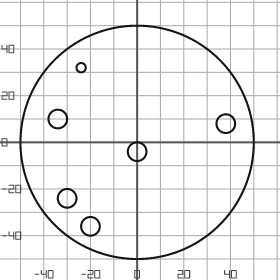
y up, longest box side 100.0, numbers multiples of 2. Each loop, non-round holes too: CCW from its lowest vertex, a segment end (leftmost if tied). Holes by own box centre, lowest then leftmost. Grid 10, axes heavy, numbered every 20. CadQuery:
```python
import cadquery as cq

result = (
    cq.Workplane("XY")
    .moveTo(0.0, 0.0)
    .circle(50.0)
    .moveTo(-20.0, -36.0)
    .circle(4.0)
    .moveTo(-30.0, -24.0)
    .circle(4.0)
    .moveTo(0.0, -4.0)
    .circle(4.0)
    .moveTo(38.0, 8.0)
    .circle(4.0)
    .moveTo(-34.0, 10.0)
    .circle(4.0)
    .moveTo(-24.0, 32.0)
    .circle(2.0)
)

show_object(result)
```